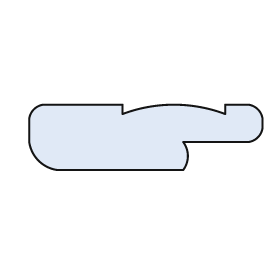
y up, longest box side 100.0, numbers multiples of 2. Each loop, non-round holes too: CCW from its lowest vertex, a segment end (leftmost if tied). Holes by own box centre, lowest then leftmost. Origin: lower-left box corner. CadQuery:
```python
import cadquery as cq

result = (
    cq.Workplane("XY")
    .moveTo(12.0, 0.0)
    .lineTo(66.0, 0.0)
    .threePointArc((68.0, 6.0), (66.0, 12.0))
    .lineTo(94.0, 12.0)
    .threePointArc((98.0, 14.0), (100.0, 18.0))
    .lineTo(100.0, 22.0)
    .threePointArc((98.0, 26.0), (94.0, 28.0))
    .lineTo(84.0, 28.0)
    .lineTo(84.0, 24.0)
    .threePointArc((62.0, 28.0), (40.0, 24.0))
    .lineTo(40.0, 28.0)
    .lineTo(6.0, 28.0)
    .threePointArc((2.0, 26.0), (0.0, 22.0))
    .lineTo(0.0, 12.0)
    .threePointArc((4.0, 4.0), (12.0, 0.0))
    .close()
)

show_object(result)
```